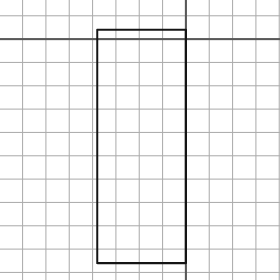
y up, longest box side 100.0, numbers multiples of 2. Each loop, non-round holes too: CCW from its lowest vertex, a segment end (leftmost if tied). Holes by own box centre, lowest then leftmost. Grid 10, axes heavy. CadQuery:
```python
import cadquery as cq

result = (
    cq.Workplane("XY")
    .moveTo(-38.0, -96.0)
    .lineTo(0.0, -96.0)
    .lineTo(0.0, 4.0)
    .lineTo(-38.0, 4.0)
    .close()
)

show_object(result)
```